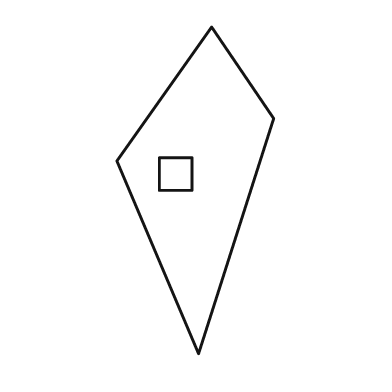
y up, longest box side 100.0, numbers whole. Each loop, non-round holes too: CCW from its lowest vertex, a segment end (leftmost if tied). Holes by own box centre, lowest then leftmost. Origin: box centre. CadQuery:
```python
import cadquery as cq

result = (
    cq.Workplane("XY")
    .moveTo(1.0, -50.0)
    .lineTo(24.0, 22.0)
    .lineTo(5.0, 50.0)
    .lineTo(-24.0, 9.0)
    .close()
    .moveTo(-11.0, 0.0)
    .lineTo(-1.0, 0.0)
    .lineTo(-1.0, 10.0)
    .lineTo(-11.0, 10.0)
    .close()
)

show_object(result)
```